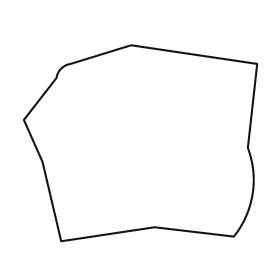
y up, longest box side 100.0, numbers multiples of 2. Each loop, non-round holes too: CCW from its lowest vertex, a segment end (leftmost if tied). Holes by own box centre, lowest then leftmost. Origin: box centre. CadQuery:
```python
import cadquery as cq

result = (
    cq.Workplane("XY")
    .moveTo(-34.0, -42.0)
    .lineTo(6.0, -36.0)
    .lineTo(40.0, -40.0)
    .threePointArc((48.0, -22.0), (46.0, -2.0))
    .lineTo(50.0, 34.0)
    .lineTo(-4.0, 42.0)
    .lineTo(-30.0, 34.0)
    .threePointArc((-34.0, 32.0), (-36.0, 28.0))
    .lineTo(-50.0, 10.0)
    .lineTo(-42.0, -8.0)
    .close()
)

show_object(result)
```